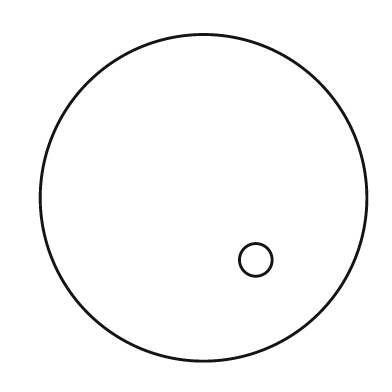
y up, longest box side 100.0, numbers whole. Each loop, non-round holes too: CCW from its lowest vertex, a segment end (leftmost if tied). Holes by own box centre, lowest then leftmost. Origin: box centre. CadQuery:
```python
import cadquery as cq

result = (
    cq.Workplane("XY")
    .moveTo(0.0, 0.0)
    .circle(50.0)
    .moveTo(16.0, -19.0)
    .circle(5.0)
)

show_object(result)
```